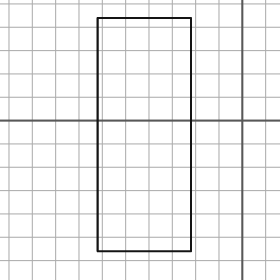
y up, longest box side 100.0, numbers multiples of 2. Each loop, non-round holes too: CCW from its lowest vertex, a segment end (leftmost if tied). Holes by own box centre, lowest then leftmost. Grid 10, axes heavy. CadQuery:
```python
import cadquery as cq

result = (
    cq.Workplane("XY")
    .moveTo(-62.0, -56.0)
    .lineTo(-22.0, -56.0)
    .lineTo(-22.0, 44.0)
    .lineTo(-62.0, 44.0)
    .close()
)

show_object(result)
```